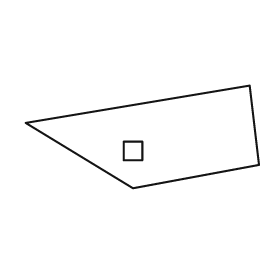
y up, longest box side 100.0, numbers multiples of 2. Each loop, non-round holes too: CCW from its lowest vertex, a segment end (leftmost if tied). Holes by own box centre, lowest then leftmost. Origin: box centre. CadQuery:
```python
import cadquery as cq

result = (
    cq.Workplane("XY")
    .moveTo(-4.0, -22.0)
    .lineTo(50.0, -12.0)
    .lineTo(46.0, 22.0)
    .lineTo(-50.0, 6.0)
    .close()
    .moveTo(-8.0, -10.0)
    .lineTo(0.0, -10.0)
    .lineTo(0.0, -2.0)
    .lineTo(-8.0, -2.0)
    .close()
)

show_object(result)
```